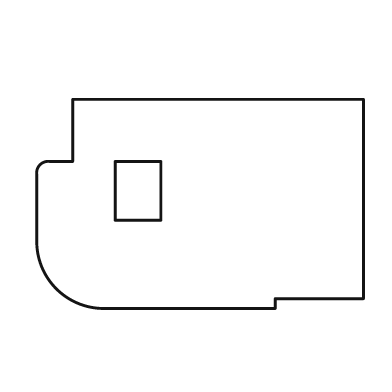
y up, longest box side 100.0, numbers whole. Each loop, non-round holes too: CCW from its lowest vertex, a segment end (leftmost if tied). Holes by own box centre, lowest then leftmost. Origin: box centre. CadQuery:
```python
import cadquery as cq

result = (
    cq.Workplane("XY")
    .moveTo(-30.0, -32.0)
    .lineTo(23.0, -32.0)
    .lineTo(23.0, -29.0)
    .lineTo(50.0, -29.0)
    .lineTo(50.0, 32.0)
    .lineTo(-39.0, 32.0)
    .lineTo(-39.0, 13.0)
    .lineTo(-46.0, 13.0)
    .threePointArc((-49.0, 12.0), (-50.0, 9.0))
    .lineTo(-50.0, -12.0)
    .threePointArc((-44.0, -26.0), (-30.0, -32.0))
    .close()
    .moveTo(-26.0, -5.0)
    .lineTo(-12.0, -5.0)
    .lineTo(-12.0, 13.0)
    .lineTo(-26.0, 13.0)
    .close()
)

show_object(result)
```